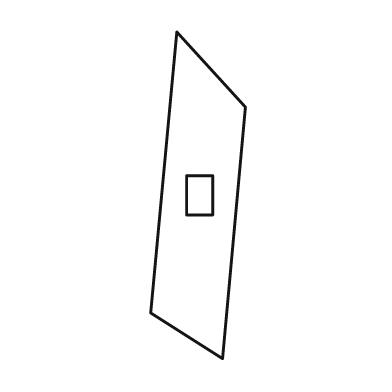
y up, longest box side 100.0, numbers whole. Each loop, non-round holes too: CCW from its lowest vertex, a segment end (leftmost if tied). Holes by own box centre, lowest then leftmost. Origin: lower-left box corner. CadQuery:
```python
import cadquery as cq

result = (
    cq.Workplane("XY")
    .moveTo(22.0, 0.0)
    .lineTo(29.0, 77.0)
    .lineTo(8.0, 100.0)
    .lineTo(0.0, 14.0)
    .close()
    .moveTo(11.0, 44.0)
    .lineTo(19.0, 44.0)
    .lineTo(19.0, 56.0)
    .lineTo(11.0, 56.0)
    .close()
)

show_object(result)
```